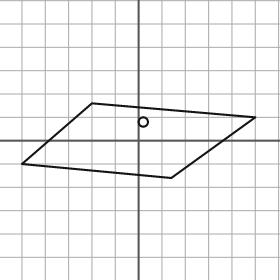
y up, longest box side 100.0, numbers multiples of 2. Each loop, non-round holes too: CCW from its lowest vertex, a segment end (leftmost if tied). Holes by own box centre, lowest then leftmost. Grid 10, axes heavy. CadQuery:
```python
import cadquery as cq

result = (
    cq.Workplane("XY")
    .moveTo(14.0, -16.0)
    .lineTo(50.0, 10.0)
    .lineTo(-20.0, 16.0)
    .lineTo(-50.0, -10.0)
    .close()
    .moveTo(2.0, 8.0)
    .circle(2.0)
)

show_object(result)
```